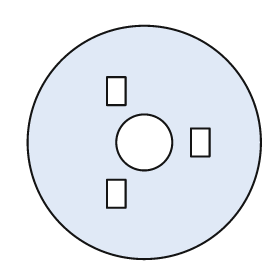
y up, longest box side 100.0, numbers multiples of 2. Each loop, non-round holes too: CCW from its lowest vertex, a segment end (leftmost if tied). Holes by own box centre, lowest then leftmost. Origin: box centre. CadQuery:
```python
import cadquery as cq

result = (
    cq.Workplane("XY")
    .moveTo(0.0, 0.0)
    .circle(50.0)
    .moveTo(-16.0, -28.0)
    .lineTo(-8.0, -28.0)
    .lineTo(-8.0, -16.0)
    .lineTo(-16.0, -16.0)
    .close()
    .moveTo(0.0, 0.0)
    .circle(12.0)
    .moveTo(20.0, -6.0)
    .lineTo(28.0, -6.0)
    .lineTo(28.0, 6.0)
    .lineTo(20.0, 6.0)
    .close()
    .moveTo(-16.0, 16.0)
    .lineTo(-8.0, 16.0)
    .lineTo(-8.0, 28.0)
    .lineTo(-16.0, 28.0)
    .close()
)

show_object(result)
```